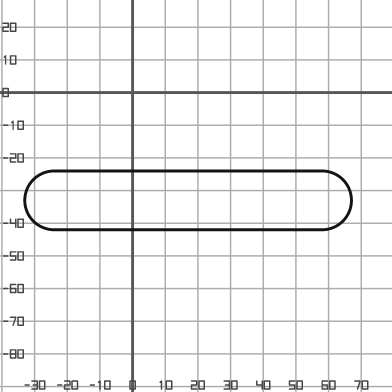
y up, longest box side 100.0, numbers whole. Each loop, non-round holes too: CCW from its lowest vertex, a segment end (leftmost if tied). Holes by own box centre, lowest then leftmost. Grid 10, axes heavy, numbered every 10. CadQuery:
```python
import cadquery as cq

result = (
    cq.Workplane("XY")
    .moveTo(-24.0, -42.0)
    .lineTo(58.0, -42.0)
    .threePointArc((67.0, -33.0), (58.0, -24.0))
    .lineTo(-24.0, -24.0)
    .threePointArc((-33.0, -33.0), (-24.0, -42.0))
    .close()
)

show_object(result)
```